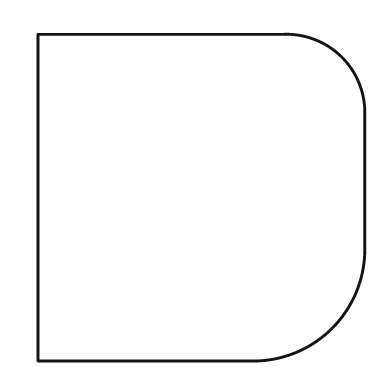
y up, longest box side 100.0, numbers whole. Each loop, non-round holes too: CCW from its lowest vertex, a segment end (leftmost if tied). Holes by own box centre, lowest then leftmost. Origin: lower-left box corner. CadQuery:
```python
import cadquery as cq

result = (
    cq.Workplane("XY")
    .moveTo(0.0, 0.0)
    .lineTo(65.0, 0.0)
    .threePointArc((90.0, 10.0), (100.0, 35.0))
    .lineTo(100.0, 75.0)
    .threePointArc((93.0, 93.0), (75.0, 100.0))
    .lineTo(0.0, 100.0)
    .close()
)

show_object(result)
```